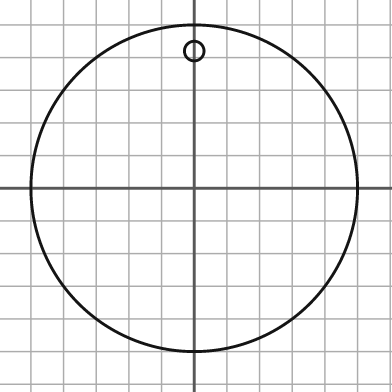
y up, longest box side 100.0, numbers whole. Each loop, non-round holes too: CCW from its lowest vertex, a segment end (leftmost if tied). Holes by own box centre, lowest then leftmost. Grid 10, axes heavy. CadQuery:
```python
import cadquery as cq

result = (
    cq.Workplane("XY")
    .moveTo(0.0, 0.0)
    .circle(50.0)
    .moveTo(0.0, 42.0)
    .circle(3.0)
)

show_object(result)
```